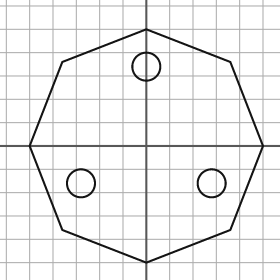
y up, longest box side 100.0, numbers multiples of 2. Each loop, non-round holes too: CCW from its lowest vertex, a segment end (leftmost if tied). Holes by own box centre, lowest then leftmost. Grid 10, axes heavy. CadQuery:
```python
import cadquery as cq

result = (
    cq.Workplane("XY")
    .moveTo(0.0, -50.0)
    .lineTo(36.0, -36.0)
    .lineTo(50.0, 0.0)
    .lineTo(36.0, 36.0)
    .lineTo(0.0, 50.0)
    .lineTo(-36.0, 36.0)
    .lineTo(-50.0, 0.0)
    .lineTo(-36.0, -36.0)
    .close()
    .moveTo(-28.0, -16.0)
    .circle(6.0)
    .moveTo(28.0, -16.0)
    .circle(6.0)
    .moveTo(0.0, 34.0)
    .circle(6.0)
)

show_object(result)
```